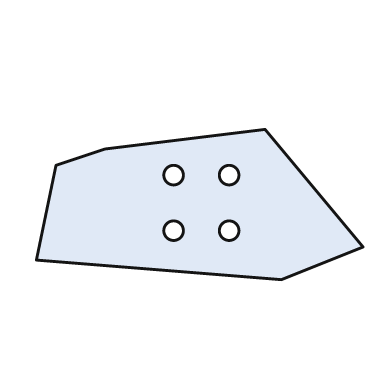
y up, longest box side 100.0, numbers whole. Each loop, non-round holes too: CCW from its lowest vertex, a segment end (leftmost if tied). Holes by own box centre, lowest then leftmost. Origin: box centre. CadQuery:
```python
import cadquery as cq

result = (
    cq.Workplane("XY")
    .moveTo(25.0, -23.0)
    .lineTo(50.0, -13.0)
    .lineTo(20.0, 23.0)
    .lineTo(-29.0, 17.0)
    .lineTo(-44.0, 12.0)
    .lineTo(-50.0, -17.0)
    .close()
    .moveTo(-8.0, -8.0)
    .circle(3.0)
    .moveTo(9.0, -8.0)
    .circle(3.0)
    .moveTo(-8.0, 9.0)
    .circle(3.0)
    .moveTo(9.0, 9.0)
    .circle(3.0)
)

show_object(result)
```